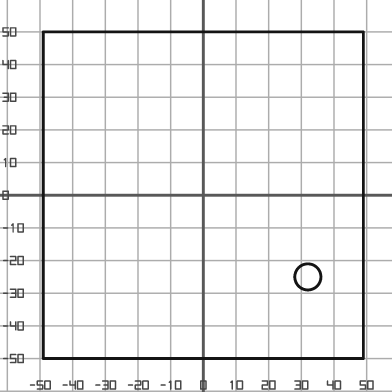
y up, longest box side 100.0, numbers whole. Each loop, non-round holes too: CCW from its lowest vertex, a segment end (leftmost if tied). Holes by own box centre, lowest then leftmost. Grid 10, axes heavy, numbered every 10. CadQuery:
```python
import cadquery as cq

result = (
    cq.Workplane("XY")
    .moveTo(-49.0, -50.0)
    .lineTo(49.0, -50.0)
    .lineTo(49.0, 50.0)
    .lineTo(-49.0, 50.0)
    .close()
    .moveTo(32.0, -25.0)
    .circle(4.0)
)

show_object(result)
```